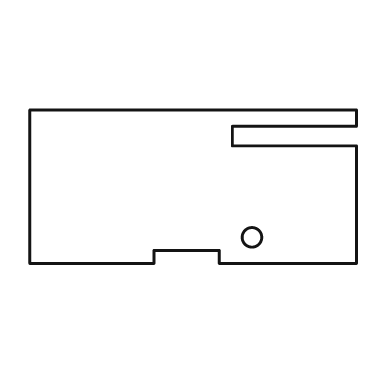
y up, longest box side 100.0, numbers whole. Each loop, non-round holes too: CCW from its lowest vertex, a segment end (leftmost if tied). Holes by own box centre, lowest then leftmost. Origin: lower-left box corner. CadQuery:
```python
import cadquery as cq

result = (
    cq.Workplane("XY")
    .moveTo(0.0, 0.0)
    .lineTo(38.0, 0.0)
    .lineTo(38.0, 4.0)
    .lineTo(58.0, 4.0)
    .lineTo(58.0, 0.0)
    .lineTo(100.0, 0.0)
    .lineTo(100.0, 36.0)
    .lineTo(62.0, 36.0)
    .lineTo(62.0, 42.0)
    .lineTo(100.0, 42.0)
    .lineTo(100.0, 47.0)
    .lineTo(0.0, 47.0)
    .close()
    .moveTo(68.0, 8.0)
    .circle(3.0)
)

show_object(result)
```